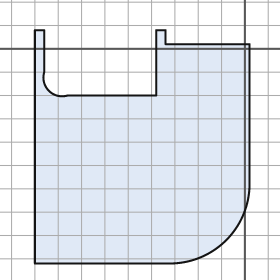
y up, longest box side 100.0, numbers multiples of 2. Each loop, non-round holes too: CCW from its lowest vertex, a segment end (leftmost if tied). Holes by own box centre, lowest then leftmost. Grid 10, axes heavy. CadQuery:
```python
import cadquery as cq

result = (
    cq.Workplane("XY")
    .moveTo(-90.0, -92.0)
    .lineTo(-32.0, -92.0)
    .threePointArc((-8.0, -82.0), (2.0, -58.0))
    .lineTo(2.0, 2.0)
    .lineTo(-34.0, 2.0)
    .lineTo(-34.0, 8.0)
    .lineTo(-38.0, 8.0)
    .lineTo(-38.0, -20.0)
    .lineTo(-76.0, -20.0)
    .threePointArc((-84.0, -18.0), (-86.0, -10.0))
    .lineTo(-86.0, 8.0)
    .lineTo(-90.0, 8.0)
    .close()
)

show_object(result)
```